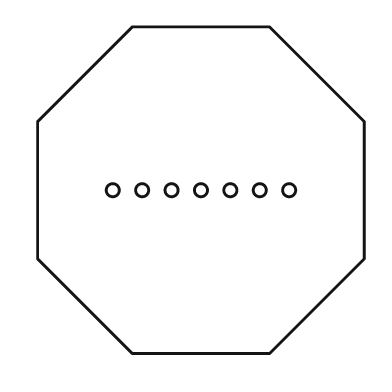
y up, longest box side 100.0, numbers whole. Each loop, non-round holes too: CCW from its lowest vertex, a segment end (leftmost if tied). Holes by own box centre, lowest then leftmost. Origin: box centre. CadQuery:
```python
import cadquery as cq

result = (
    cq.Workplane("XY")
    .moveTo(-21.0, -50.0)
    .lineTo(21.0, -50.0)
    .lineTo(50.0, -21.0)
    .lineTo(50.0, 21.0)
    .lineTo(21.0, 50.0)
    .lineTo(-21.0, 50.0)
    .lineTo(-50.0, 21.0)
    .lineTo(-50.0, -21.0)
    .close()
    .moveTo(-27.0, 0.0)
    .circle(2.0)
    .moveTo(-18.0, 0.0)
    .circle(2.0)
    .moveTo(-9.0, 0.0)
    .circle(2.0)
    .moveTo(0.0, 0.0)
    .circle(2.0)
    .moveTo(9.0, 0.0)
    .circle(2.0)
    .moveTo(18.0, 0.0)
    .circle(2.0)
    .moveTo(27.0, 0.0)
    .circle(2.0)
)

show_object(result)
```